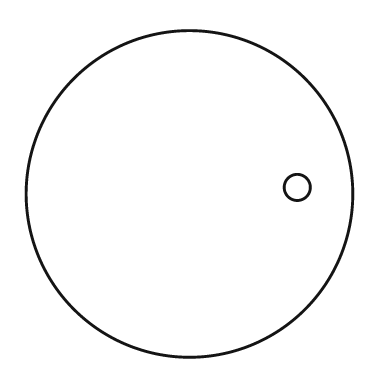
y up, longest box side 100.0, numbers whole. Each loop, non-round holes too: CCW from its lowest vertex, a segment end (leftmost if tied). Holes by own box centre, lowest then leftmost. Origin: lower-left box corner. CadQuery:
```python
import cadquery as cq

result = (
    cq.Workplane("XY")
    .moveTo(50.0, 50.0)
    .circle(50.0)
    .moveTo(83.0, 52.0)
    .circle(4.0)
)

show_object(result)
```